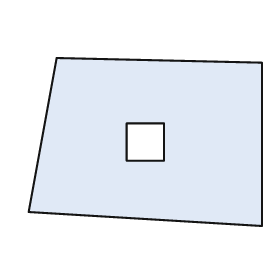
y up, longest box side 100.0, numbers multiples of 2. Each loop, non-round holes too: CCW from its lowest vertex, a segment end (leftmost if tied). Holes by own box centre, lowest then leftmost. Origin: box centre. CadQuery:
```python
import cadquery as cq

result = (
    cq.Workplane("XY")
    .moveTo(50.0, -36.0)
    .lineTo(50.0, 34.0)
    .lineTo(-38.0, 36.0)
    .lineTo(-50.0, -30.0)
    .close()
    .moveTo(-8.0, -8.0)
    .lineTo(8.0, -8.0)
    .lineTo(8.0, 8.0)
    .lineTo(-8.0, 8.0)
    .close()
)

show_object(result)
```